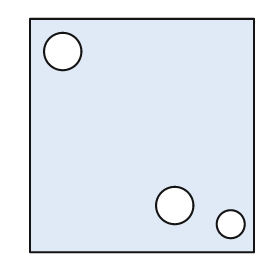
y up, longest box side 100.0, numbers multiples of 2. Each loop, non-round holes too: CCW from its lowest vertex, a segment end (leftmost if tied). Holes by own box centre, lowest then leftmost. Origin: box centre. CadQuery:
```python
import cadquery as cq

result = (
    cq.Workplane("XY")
    .moveTo(-48.0, -50.0)
    .lineTo(48.0, -50.0)
    .lineTo(48.0, 50.0)
    .lineTo(-48.0, 50.0)
    .close()
    .moveTo(38.0, -38.0)
    .circle(6.0)
    .moveTo(14.0, -30.0)
    .circle(8.0)
    .moveTo(-34.0, 36.0)
    .circle(8.0)
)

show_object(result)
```